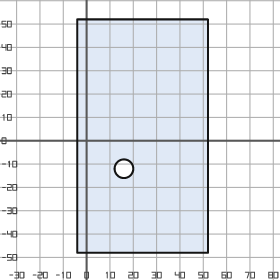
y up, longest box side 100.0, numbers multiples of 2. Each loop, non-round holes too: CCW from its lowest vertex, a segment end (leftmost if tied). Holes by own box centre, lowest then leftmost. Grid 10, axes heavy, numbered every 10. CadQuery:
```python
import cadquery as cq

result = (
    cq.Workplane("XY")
    .moveTo(-4.0, -48.0)
    .lineTo(52.0, -48.0)
    .lineTo(52.0, 52.0)
    .lineTo(-4.0, 52.0)
    .close()
    .moveTo(16.0, -12.0)
    .circle(4.0)
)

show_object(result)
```